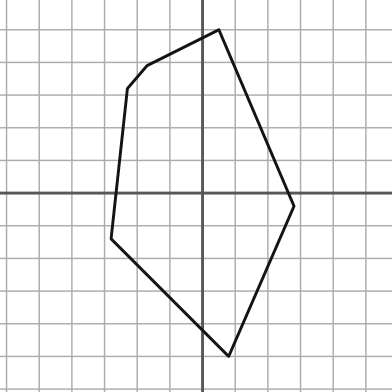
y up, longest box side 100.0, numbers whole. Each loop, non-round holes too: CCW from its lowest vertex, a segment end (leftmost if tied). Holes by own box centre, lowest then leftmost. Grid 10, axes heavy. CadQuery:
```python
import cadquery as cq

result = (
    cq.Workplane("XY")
    .moveTo(8.0, -50.0)
    .lineTo(28.0, -4.0)
    .lineTo(5.0, 50.0)
    .lineTo(-17.0, 39.0)
    .lineTo(-23.0, 32.0)
    .lineTo(-28.0, -14.0)
    .close()
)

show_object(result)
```